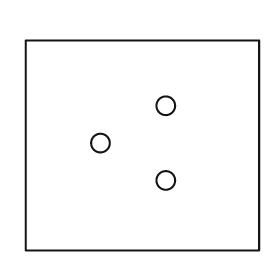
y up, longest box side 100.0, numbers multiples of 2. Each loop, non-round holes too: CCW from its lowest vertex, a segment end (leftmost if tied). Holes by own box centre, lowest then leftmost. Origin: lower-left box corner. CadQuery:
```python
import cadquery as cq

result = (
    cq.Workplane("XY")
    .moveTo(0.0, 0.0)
    .lineTo(100.0, 0.0)
    .lineTo(100.0, 90.0)
    .lineTo(0.0, 90.0)
    .close()
    .moveTo(60.0, 30.0)
    .circle(4.0)
    .moveTo(32.0, 46.0)
    .circle(4.0)
    .moveTo(60.0, 62.0)
    .circle(4.0)
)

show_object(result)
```